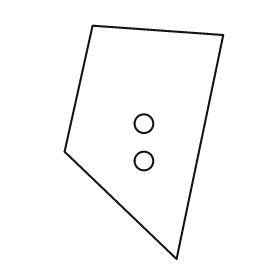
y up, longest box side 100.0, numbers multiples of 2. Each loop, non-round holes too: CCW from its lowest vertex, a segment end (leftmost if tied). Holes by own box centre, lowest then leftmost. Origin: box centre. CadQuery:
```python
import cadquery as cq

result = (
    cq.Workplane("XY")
    .moveTo(14.0, -50.0)
    .lineTo(34.0, 46.0)
    .lineTo(-22.0, 50.0)
    .lineTo(-34.0, -4.0)
    .close()
    .moveTo(0.0, -8.0)
    .circle(4.0)
    .moveTo(0.0, 8.0)
    .circle(4.0)
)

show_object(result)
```